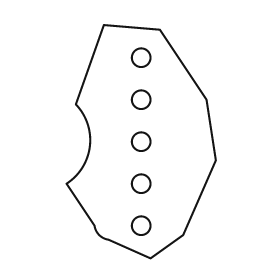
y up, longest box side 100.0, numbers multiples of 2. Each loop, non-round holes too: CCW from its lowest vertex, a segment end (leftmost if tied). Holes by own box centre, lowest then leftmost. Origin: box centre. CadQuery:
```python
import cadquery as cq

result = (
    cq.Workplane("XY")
    .moveTo(4.0, -50.0)
    .lineTo(18.0, -40.0)
    .lineTo(32.0, -8.0)
    .lineTo(28.0, 18.0)
    .lineTo(8.0, 48.0)
    .lineTo(-16.0, 50.0)
    .lineTo(-28.0, 16.0)
    .threePointArc((-22.0, -2.0), (-32.0, -18.0))
    .lineTo(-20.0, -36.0)
    .threePointArc((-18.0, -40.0), (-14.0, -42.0))
    .close()
    .moveTo(0.0, -36.0)
    .circle(4.0)
    .moveTo(0.0, -18.0)
    .circle(4.0)
    .moveTo(0.0, 0.0)
    .circle(4.0)
    .moveTo(0.0, 18.0)
    .circle(4.0)
    .moveTo(0.0, 36.0)
    .circle(4.0)
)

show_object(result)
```